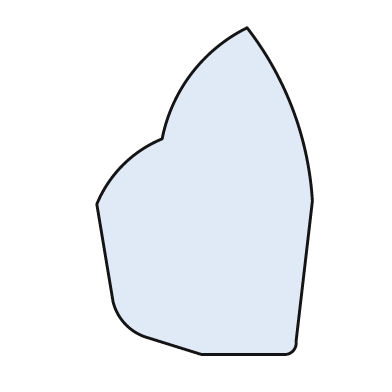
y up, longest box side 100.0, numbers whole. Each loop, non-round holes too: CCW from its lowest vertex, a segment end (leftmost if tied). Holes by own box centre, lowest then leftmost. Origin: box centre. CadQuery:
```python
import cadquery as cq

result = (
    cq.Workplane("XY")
    .moveTo(-1.0, -50.0)
    .lineTo(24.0, -50.0)
    .threePointArc((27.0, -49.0), (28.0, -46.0))
    .lineTo(33.0, -3.0)
    .threePointArc((27.0, 25.0), (13.0, 50.0))
    .threePointArc((-4.0, 36.0), (-13.0, 16.0))
    .threePointArc((-25.0, 8.0), (-33.0, -4.0))
    .lineTo(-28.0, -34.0)
    .threePointArc((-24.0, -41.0), (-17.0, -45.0))
    .close()
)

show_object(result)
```